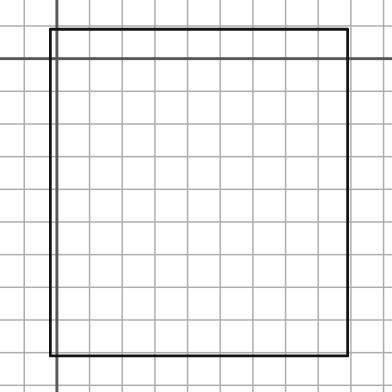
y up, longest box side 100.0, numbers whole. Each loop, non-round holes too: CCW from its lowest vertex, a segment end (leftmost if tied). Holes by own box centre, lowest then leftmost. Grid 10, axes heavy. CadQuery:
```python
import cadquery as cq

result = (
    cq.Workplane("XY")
    .moveTo(-2.0, -91.0)
    .lineTo(89.0, -91.0)
    .lineTo(89.0, 9.0)
    .lineTo(-2.0, 9.0)
    .close()
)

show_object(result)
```